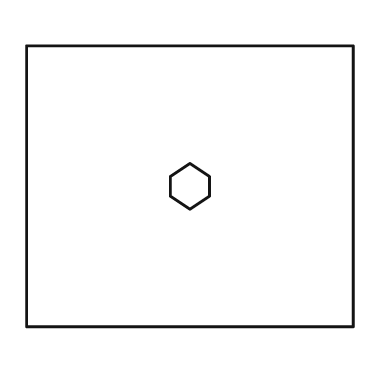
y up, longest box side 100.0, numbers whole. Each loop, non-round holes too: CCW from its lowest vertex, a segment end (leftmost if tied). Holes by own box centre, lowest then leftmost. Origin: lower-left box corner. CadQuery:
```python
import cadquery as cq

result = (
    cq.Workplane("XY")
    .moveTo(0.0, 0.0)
    .lineTo(100.0, 0.0)
    .lineTo(100.0, 86.0)
    .lineTo(0.0, 86.0)
    .close()
    .moveTo(50.0, 36.0)
    .lineTo(56.0, 40.0)
    .lineTo(56.0, 46.0)
    .lineTo(50.0, 50.0)
    .lineTo(44.0, 46.0)
    .lineTo(44.0, 40.0)
    .close()
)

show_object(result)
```